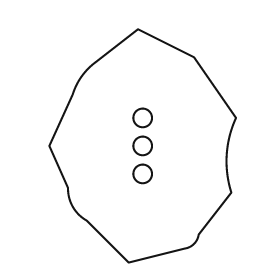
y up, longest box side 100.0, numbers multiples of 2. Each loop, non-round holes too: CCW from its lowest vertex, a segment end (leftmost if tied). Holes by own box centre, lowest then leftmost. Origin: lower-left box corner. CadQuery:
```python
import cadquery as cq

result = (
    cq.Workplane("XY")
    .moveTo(34.0, 0.0)
    .lineTo(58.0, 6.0)
    .threePointArc((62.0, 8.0), (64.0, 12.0))
    .lineTo(78.0, 30.0)
    .threePointArc((76.0, 46.0), (80.0, 62.0))
    .lineTo(62.0, 88.0)
    .lineTo(38.0, 100.0)
    .lineTo(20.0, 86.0)
    .threePointArc((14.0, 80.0), (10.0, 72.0))
    .lineTo(0.0, 50.0)
    .lineTo(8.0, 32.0)
    .threePointArc((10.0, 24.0), (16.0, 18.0))
    .close()
    .moveTo(40.0, 38.0)
    .circle(4.0)
    .moveTo(40.0, 50.0)
    .circle(4.0)
    .moveTo(40.0, 62.0)
    .circle(4.0)
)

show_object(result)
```